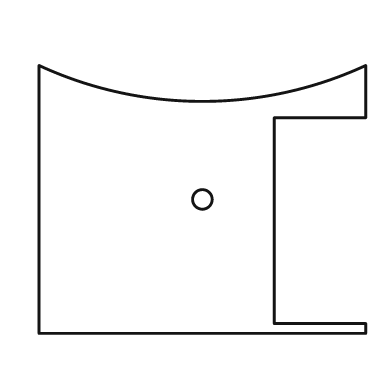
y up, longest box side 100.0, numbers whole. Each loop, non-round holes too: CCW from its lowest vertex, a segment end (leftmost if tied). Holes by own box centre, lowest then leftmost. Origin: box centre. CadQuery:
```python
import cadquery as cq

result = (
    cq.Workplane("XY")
    .moveTo(-50.0, -41.0)
    .lineTo(50.0, -41.0)
    .lineTo(50.0, -38.0)
    .lineTo(22.0, -38.0)
    .lineTo(22.0, 25.0)
    .lineTo(50.0, 25.0)
    .lineTo(50.0, 41.0)
    .threePointArc((0.0, 30.0), (-50.0, 41.0))
    .close()
    .moveTo(0.0, 0.0)
    .circle(3.0)
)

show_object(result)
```